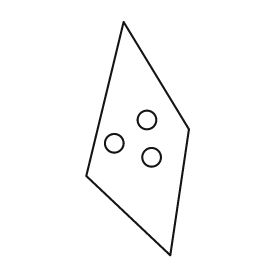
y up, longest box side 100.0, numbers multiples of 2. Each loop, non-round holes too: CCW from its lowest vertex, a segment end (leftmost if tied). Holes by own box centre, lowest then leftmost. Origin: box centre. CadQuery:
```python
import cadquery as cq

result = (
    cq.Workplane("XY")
    .moveTo(14.0, -50.0)
    .lineTo(22.0, 4.0)
    .lineTo(-6.0, 50.0)
    .lineTo(-22.0, -16.0)
    .close()
    .moveTo(6.0, -8.0)
    .circle(4.0)
    .moveTo(-10.0, -2.0)
    .circle(4.0)
    .moveTo(4.0, 8.0)
    .circle(4.0)
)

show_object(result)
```